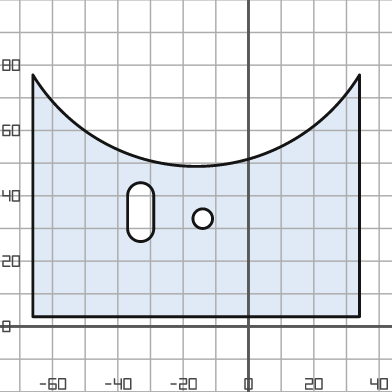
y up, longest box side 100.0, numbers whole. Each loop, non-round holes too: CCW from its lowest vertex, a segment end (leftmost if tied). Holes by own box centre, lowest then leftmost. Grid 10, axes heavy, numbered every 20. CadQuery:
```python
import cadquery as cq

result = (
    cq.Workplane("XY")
    .moveTo(-66.0, 3.0)
    .lineTo(34.0, 3.0)
    .lineTo(34.0, 77.0)
    .threePointArc((-16.0, 49.0), (-66.0, 77.0))
    .close()
    .moveTo(-14.0, 33.0)
    .circle(3.0)
    .moveTo(-37.0, 30.0)
    .threePointArc((-33.0, 26.0), (-29.0, 30.0))
    .lineTo(-29.0, 40.0)
    .threePointArc((-33.0, 44.0), (-37.0, 40.0))
    .close()
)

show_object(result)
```